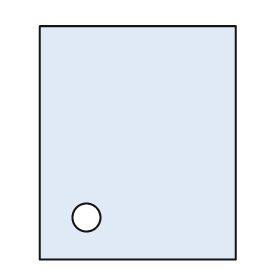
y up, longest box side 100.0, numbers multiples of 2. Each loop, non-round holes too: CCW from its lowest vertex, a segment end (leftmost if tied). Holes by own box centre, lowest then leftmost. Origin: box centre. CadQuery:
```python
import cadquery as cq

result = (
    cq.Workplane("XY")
    .moveTo(-42.0, -50.0)
    .lineTo(42.0, -50.0)
    .lineTo(42.0, 50.0)
    .lineTo(-42.0, 50.0)
    .close()
    .moveTo(-22.0, -32.0)
    .circle(6.0)
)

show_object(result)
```